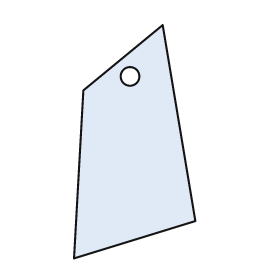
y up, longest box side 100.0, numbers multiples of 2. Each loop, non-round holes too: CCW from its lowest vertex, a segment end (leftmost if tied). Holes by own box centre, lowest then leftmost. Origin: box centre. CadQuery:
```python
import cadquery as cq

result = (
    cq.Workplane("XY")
    .moveTo(-26.0, -50.0)
    .lineTo(26.0, -34.0)
    .lineTo(12.0, 50.0)
    .lineTo(-22.0, 22.0)
    .close()
    .moveTo(-2.0, 28.0)
    .circle(4.0)
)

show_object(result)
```